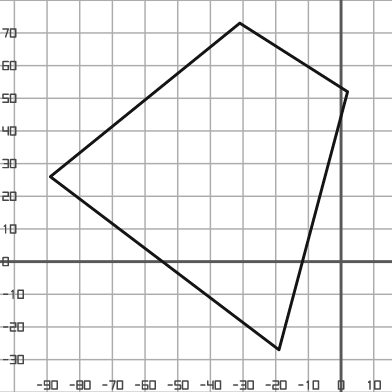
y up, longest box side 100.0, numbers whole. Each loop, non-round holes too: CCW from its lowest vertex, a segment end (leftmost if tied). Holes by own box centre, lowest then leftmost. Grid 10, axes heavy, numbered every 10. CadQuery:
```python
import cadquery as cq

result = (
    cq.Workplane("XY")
    .moveTo(-19.0, -27.0)
    .lineTo(2.0, 52.0)
    .lineTo(-31.0, 73.0)
    .lineTo(-89.0, 26.0)
    .close()
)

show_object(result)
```